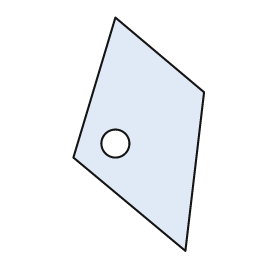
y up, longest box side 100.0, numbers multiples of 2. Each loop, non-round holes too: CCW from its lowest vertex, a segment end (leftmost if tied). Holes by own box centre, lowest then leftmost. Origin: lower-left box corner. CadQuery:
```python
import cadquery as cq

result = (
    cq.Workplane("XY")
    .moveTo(48.0, 0.0)
    .lineTo(56.0, 68.0)
    .lineTo(18.0, 100.0)
    .lineTo(0.0, 40.0)
    .close()
    .moveTo(18.0, 46.0)
    .circle(6.0)
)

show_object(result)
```